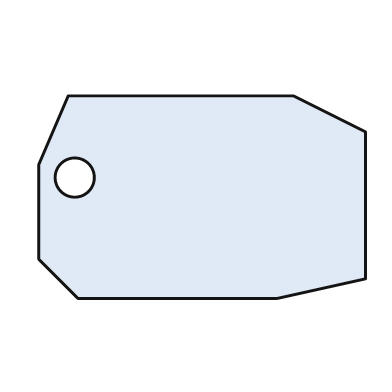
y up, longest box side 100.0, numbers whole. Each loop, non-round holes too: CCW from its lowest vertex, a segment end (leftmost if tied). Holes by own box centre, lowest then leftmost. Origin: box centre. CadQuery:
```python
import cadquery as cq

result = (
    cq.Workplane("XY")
    .moveTo(-38.0, -31.0)
    .lineTo(23.0, -31.0)
    .lineTo(50.0, -25.0)
    .lineTo(50.0, 20.0)
    .lineTo(28.0, 31.0)
    .lineTo(-41.0, 31.0)
    .lineTo(-50.0, 10.0)
    .lineTo(-50.0, -19.0)
    .close()
    .moveTo(-39.0, 6.0)
    .circle(6.0)
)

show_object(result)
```